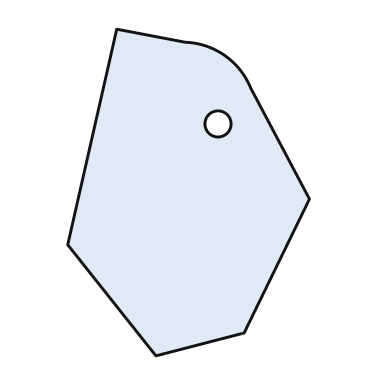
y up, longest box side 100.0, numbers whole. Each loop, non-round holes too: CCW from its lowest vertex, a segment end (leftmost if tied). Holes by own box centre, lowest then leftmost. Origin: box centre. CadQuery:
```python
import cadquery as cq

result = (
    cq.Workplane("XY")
    .moveTo(-10.0, -50.0)
    .lineTo(17.0, -43.0)
    .lineTo(37.0, -2.0)
    .lineTo(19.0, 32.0)
    .threePointArc((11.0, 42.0), (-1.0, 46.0))
    .lineTo(-22.0, 50.0)
    .lineTo(-37.0, -16.0)
    .close()
    .moveTo(9.0, 21.0)
    .circle(4.0)
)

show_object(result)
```